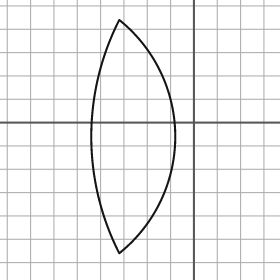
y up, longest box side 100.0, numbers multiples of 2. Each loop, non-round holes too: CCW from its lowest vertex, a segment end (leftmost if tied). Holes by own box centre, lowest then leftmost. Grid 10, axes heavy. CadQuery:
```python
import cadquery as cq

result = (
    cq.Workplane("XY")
    .moveTo(-32.0, -56.0)
    .threePointArc((-8.0, -6.0), (-32.0, 44.0))
    .threePointArc((-44.0, -6.0), (-32.0, -56.0))
    .close()
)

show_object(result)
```